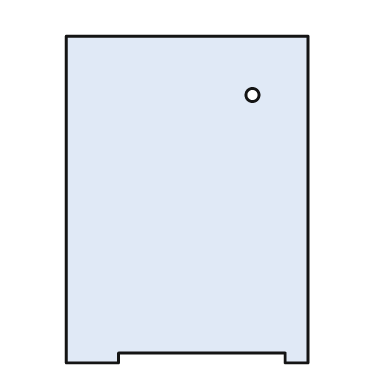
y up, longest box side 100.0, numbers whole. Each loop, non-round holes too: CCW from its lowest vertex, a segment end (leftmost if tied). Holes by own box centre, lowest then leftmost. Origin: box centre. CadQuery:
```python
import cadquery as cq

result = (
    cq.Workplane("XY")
    .moveTo(-37.0, -50.0)
    .lineTo(-21.0, -50.0)
    .lineTo(-21.0, -47.0)
    .lineTo(30.0, -47.0)
    .lineTo(30.0, -50.0)
    .lineTo(37.0, -50.0)
    .lineTo(37.0, 50.0)
    .lineTo(-37.0, 50.0)
    .close()
    .moveTo(20.0, 32.0)
    .circle(2.0)
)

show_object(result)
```